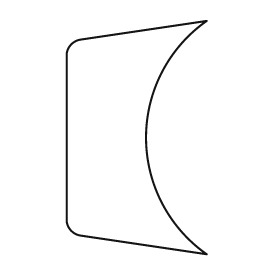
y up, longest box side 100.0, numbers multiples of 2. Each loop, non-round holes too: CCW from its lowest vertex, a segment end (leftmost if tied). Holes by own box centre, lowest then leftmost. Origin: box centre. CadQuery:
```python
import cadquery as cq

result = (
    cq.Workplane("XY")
    .moveTo(30.0, -50.0)
    .threePointArc((4.0, 0.0), (30.0, 50.0))
    .lineTo(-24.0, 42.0)
    .threePointArc((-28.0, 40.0), (-30.0, 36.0))
    .lineTo(-30.0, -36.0)
    .threePointArc((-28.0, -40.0), (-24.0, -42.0))
    .close()
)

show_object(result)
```